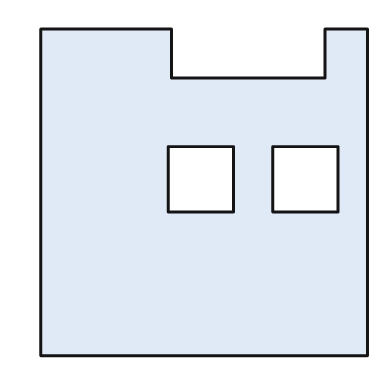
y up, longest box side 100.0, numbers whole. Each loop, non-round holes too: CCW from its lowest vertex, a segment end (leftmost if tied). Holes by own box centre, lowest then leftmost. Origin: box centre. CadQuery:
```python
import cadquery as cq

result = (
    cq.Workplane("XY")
    .moveTo(-50.0, -50.0)
    .lineTo(50.0, -50.0)
    .lineTo(50.0, 50.0)
    .lineTo(37.0, 50.0)
    .lineTo(37.0, 35.0)
    .lineTo(-10.0, 35.0)
    .lineTo(-10.0, 50.0)
    .lineTo(-50.0, 50.0)
    .close()
    .moveTo(-11.0, -6.0)
    .lineTo(9.0, -6.0)
    .lineTo(9.0, 14.0)
    .lineTo(-11.0, 14.0)
    .close()
    .moveTo(21.0, -6.0)
    .lineTo(41.0, -6.0)
    .lineTo(41.0, 14.0)
    .lineTo(21.0, 14.0)
    .close()
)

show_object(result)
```